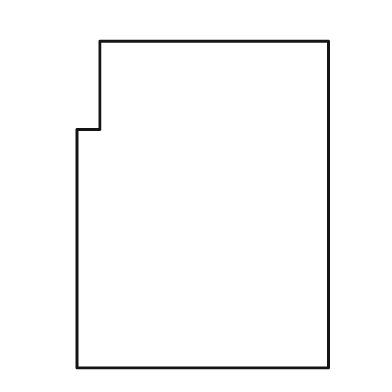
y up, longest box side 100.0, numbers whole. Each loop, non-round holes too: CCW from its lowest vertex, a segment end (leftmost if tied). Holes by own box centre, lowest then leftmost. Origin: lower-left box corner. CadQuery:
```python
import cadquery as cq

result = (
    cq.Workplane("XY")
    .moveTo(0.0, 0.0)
    .lineTo(77.0, 0.0)
    .lineTo(77.0, 100.0)
    .lineTo(7.0, 100.0)
    .lineTo(7.0, 73.0)
    .lineTo(0.0, 73.0)
    .close()
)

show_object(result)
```